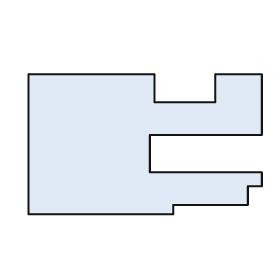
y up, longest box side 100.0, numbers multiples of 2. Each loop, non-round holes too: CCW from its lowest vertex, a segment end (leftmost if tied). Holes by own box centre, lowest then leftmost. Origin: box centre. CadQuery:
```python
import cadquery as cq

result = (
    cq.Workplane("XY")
    .moveTo(-50.0, -30.0)
    .lineTo(12.0, -30.0)
    .lineTo(12.0, -26.0)
    .lineTo(44.0, -26.0)
    .lineTo(44.0, -18.0)
    .lineTo(50.0, -18.0)
    .lineTo(50.0, -12.0)
    .lineTo(2.0, -12.0)
    .lineTo(2.0, 4.0)
    .lineTo(50.0, 4.0)
    .lineTo(50.0, 30.0)
    .lineTo(30.0, 30.0)
    .lineTo(30.0, 18.0)
    .lineTo(4.0, 18.0)
    .lineTo(4.0, 30.0)
    .lineTo(-50.0, 30.0)
    .close()
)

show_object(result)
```